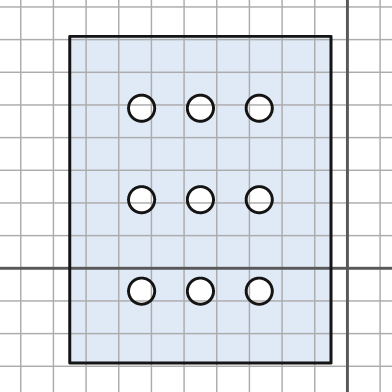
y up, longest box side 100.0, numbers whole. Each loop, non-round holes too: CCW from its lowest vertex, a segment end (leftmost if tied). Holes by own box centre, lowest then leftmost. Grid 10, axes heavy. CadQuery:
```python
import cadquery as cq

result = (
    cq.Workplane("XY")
    .moveTo(-85.0, -29.0)
    .lineTo(-5.0, -29.0)
    .lineTo(-5.0, 71.0)
    .lineTo(-85.0, 71.0)
    .close()
    .moveTo(-63.0, -7.0)
    .circle(4.0)
    .moveTo(-45.0, -7.0)
    .circle(4.0)
    .moveTo(-27.0, -7.0)
    .circle(4.0)
    .moveTo(-63.0, 21.0)
    .circle(4.0)
    .moveTo(-45.0, 21.0)
    .circle(4.0)
    .moveTo(-27.0, 21.0)
    .circle(4.0)
    .moveTo(-63.0, 49.0)
    .circle(4.0)
    .moveTo(-45.0, 49.0)
    .circle(4.0)
    .moveTo(-27.0, 49.0)
    .circle(4.0)
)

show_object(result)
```